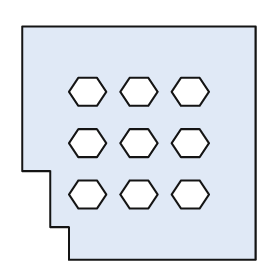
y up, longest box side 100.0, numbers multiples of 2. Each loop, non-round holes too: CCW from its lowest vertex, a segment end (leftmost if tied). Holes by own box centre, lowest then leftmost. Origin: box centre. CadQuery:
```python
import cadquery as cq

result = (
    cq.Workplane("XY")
    .moveTo(-30.0, -50.0)
    .lineTo(50.0, -50.0)
    .lineTo(50.0, 50.0)
    .lineTo(-50.0, 50.0)
    .lineTo(-50.0, -12.0)
    .lineTo(-38.0, -12.0)
    .lineTo(-38.0, -36.0)
    .lineTo(-30.0, -36.0)
    .close()
    .moveTo(-26.0, -28.0)
    .lineTo(-18.0, -28.0)
    .lineTo(-14.0, -22.0)
    .lineTo(-18.0, -16.0)
    .lineTo(-26.0, -16.0)
    .lineTo(-30.0, -22.0)
    .close()
    .moveTo(-4.0, -28.0)
    .lineTo(4.0, -28.0)
    .lineTo(8.0, -22.0)
    .lineTo(4.0, -16.0)
    .lineTo(-4.0, -16.0)
    .lineTo(-8.0, -22.0)
    .close()
    .moveTo(18.0, -28.0)
    .lineTo(26.0, -28.0)
    .lineTo(30.0, -22.0)
    .lineTo(26.0, -16.0)
    .lineTo(18.0, -16.0)
    .lineTo(14.0, -22.0)
    .close()
    .moveTo(-26.0, -6.0)
    .lineTo(-18.0, -6.0)
    .lineTo(-14.0, 0.0)
    .lineTo(-18.0, 6.0)
    .lineTo(-26.0, 6.0)
    .lineTo(-30.0, 0.0)
    .close()
    .moveTo(-4.0, -6.0)
    .lineTo(4.0, -6.0)
    .lineTo(8.0, 0.0)
    .lineTo(4.0, 6.0)
    .lineTo(-4.0, 6.0)
    .lineTo(-8.0, 0.0)
    .close()
    .moveTo(18.0, -6.0)
    .lineTo(26.0, -6.0)
    .lineTo(30.0, 0.0)
    .lineTo(26.0, 6.0)
    .lineTo(18.0, 6.0)
    .lineTo(14.0, 0.0)
    .close()
    .moveTo(-26.0, 16.0)
    .lineTo(-18.0, 16.0)
    .lineTo(-14.0, 22.0)
    .lineTo(-18.0, 28.0)
    .lineTo(-26.0, 28.0)
    .lineTo(-30.0, 22.0)
    .close()
    .moveTo(-4.0, 16.0)
    .lineTo(4.0, 16.0)
    .lineTo(8.0, 22.0)
    .lineTo(4.0, 28.0)
    .lineTo(-4.0, 28.0)
    .lineTo(-8.0, 22.0)
    .close()
    .moveTo(18.0, 16.0)
    .lineTo(26.0, 16.0)
    .lineTo(30.0, 22.0)
    .lineTo(26.0, 28.0)
    .lineTo(18.0, 28.0)
    .lineTo(14.0, 22.0)
    .close()
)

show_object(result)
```